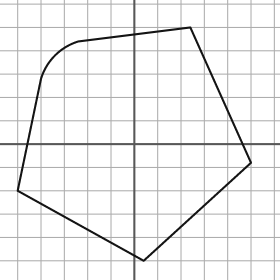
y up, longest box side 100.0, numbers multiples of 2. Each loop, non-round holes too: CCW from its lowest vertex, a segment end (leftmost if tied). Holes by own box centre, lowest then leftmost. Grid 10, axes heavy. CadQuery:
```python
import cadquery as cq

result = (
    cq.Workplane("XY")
    .moveTo(4.0, -50.0)
    .lineTo(50.0, -8.0)
    .lineTo(24.0, 50.0)
    .lineTo(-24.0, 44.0)
    .threePointArc((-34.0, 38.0), (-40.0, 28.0))
    .lineTo(-50.0, -20.0)
    .close()
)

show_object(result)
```